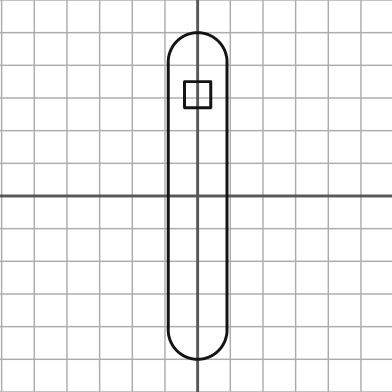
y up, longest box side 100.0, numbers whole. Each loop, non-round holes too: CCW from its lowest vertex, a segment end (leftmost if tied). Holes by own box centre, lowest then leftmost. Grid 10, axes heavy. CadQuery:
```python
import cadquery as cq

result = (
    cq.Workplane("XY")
    .moveTo(-9.0, -41.0)
    .threePointArc((0.0, -50.0), (9.0, -41.0))
    .lineTo(9.0, 41.0)
    .threePointArc((0.0, 50.0), (-9.0, 41.0))
    .close()
    .moveTo(-4.0, 27.0)
    .lineTo(4.0, 27.0)
    .lineTo(4.0, 35.0)
    .lineTo(-4.0, 35.0)
    .close()
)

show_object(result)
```